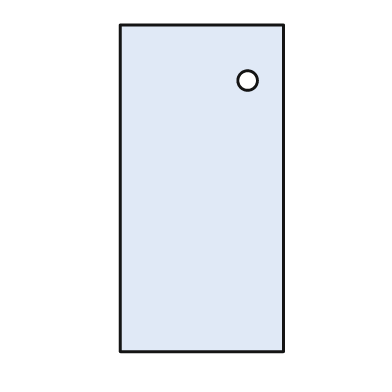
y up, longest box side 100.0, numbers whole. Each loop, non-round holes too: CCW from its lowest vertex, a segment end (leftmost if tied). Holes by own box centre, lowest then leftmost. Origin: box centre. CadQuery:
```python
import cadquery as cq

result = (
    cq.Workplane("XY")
    .moveTo(-25.0, -50.0)
    .lineTo(25.0, -50.0)
    .lineTo(25.0, 50.0)
    .lineTo(-25.0, 50.0)
    .close()
    .moveTo(14.0, 33.0)
    .circle(3.0)
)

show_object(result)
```